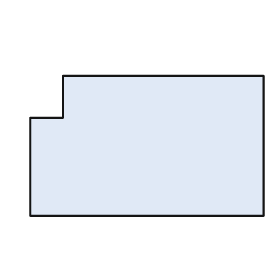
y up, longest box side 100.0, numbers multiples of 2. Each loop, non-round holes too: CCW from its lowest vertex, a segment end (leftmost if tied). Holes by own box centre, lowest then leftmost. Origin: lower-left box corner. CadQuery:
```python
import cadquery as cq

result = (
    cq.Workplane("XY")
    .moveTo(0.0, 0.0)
    .lineTo(100.0, 0.0)
    .lineTo(100.0, 60.0)
    .lineTo(14.0, 60.0)
    .lineTo(14.0, 42.0)
    .lineTo(0.0, 42.0)
    .close()
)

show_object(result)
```